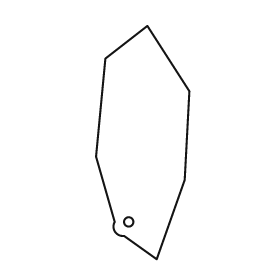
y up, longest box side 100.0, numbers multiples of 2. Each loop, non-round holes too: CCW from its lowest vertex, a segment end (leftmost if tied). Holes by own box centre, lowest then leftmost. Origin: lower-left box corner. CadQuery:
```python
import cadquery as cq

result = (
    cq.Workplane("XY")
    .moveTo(26.0, 0.0)
    .lineTo(38.0, 34.0)
    .lineTo(40.0, 72.0)
    .lineTo(22.0, 100.0)
    .lineTo(4.0, 86.0)
    .lineTo(0.0, 44.0)
    .lineTo(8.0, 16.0)
    .threePointArc((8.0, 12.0), (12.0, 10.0))
    .close()
    .moveTo(14.0, 16.0)
    .circle(2.0)
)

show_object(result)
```